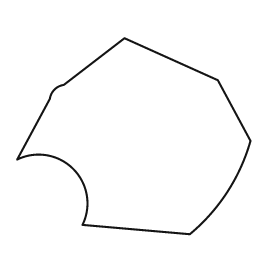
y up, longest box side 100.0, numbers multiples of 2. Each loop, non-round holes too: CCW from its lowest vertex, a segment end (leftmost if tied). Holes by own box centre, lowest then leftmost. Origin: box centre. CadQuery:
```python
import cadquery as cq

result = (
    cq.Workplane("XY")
    .moveTo(24.0, -42.0)
    .threePointArc((40.0, -24.0), (50.0, -2.0))
    .lineTo(36.0, 24.0)
    .lineTo(-4.0, 42.0)
    .lineTo(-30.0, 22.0)
    .threePointArc((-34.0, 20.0), (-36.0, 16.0))
    .lineTo(-50.0, -10.0)
    .threePointArc((-26.0, -14.0), (-22.0, -38.0))
    .close()
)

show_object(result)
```